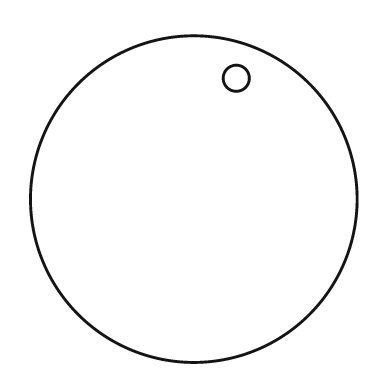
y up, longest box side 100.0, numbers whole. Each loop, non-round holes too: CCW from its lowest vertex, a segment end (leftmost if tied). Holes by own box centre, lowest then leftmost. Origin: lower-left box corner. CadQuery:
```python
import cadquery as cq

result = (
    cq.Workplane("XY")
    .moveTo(50.0, 50.0)
    .circle(50.0)
    .moveTo(63.0, 87.0)
    .circle(4.0)
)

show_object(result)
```